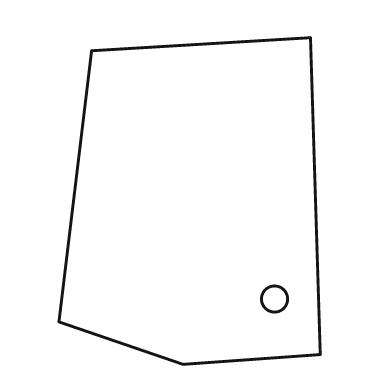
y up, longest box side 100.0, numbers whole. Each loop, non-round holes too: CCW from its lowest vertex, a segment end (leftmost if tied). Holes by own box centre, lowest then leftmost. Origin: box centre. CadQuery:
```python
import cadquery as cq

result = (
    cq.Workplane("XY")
    .moveTo(-2.0, -50.0)
    .lineTo(40.0, -47.0)
    .lineTo(37.0, 50.0)
    .lineTo(-30.0, 46.0)
    .lineTo(-40.0, -37.0)
    .close()
    .moveTo(26.0, -30.0)
    .circle(4.0)
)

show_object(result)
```